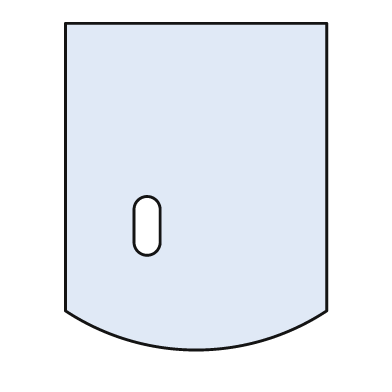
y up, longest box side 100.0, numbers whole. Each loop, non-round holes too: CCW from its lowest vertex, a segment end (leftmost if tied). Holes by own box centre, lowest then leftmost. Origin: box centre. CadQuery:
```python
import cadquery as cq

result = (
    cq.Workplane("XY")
    .moveTo(-40.0, -38.0)
    .threePointArc((0.0, -50.0), (40.0, -38.0))
    .lineTo(40.0, 50.0)
    .lineTo(-40.0, 50.0)
    .close()
    .moveTo(-19.0, -17.0)
    .threePointArc((-15.0, -21.0), (-11.0, -17.0))
    .lineTo(-11.0, -7.0)
    .threePointArc((-15.0, -3.0), (-19.0, -7.0))
    .close()
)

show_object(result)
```